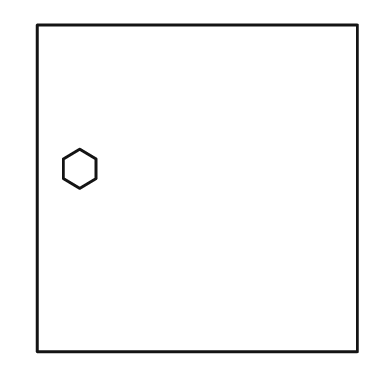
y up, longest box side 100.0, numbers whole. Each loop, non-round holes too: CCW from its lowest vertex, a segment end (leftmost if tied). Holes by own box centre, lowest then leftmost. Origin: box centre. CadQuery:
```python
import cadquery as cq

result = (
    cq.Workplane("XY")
    .moveTo(-49.0, -50.0)
    .lineTo(49.0, -50.0)
    .lineTo(49.0, 50.0)
    .lineTo(-49.0, 50.0)
    .close()
    .moveTo(-36.0, 0.0)
    .lineTo(-31.0, 3.0)
    .lineTo(-31.0, 9.0)
    .lineTo(-36.0, 12.0)
    .lineTo(-41.0, 9.0)
    .lineTo(-41.0, 3.0)
    .close()
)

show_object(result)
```